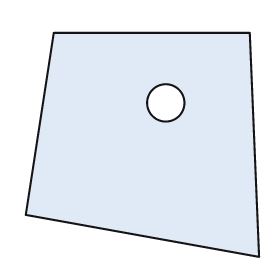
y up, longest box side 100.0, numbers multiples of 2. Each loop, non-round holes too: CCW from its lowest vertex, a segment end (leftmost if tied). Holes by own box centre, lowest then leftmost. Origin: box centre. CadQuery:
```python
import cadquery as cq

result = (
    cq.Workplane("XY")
    .moveTo(50.0, -48.0)
    .lineTo(46.0, 48.0)
    .lineTo(-38.0, 48.0)
    .lineTo(-50.0, -30.0)
    .close()
    .moveTo(10.0, 18.0)
    .circle(8.0)
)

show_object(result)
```